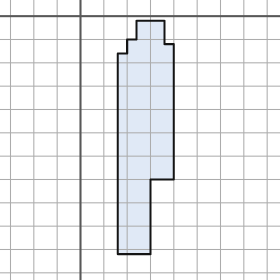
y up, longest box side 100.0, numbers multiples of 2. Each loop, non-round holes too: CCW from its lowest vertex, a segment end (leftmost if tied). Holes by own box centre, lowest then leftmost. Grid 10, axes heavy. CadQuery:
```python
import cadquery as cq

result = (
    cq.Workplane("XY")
    .moveTo(16.0, -102.0)
    .lineTo(30.0, -102.0)
    .lineTo(30.0, -70.0)
    .lineTo(40.0, -70.0)
    .lineTo(40.0, -12.0)
    .lineTo(36.0, -12.0)
    .lineTo(36.0, -2.0)
    .lineTo(24.0, -2.0)
    .lineTo(24.0, -10.0)
    .lineTo(20.0, -10.0)
    .lineTo(20.0, -16.0)
    .lineTo(16.0, -16.0)
    .close()
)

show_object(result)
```